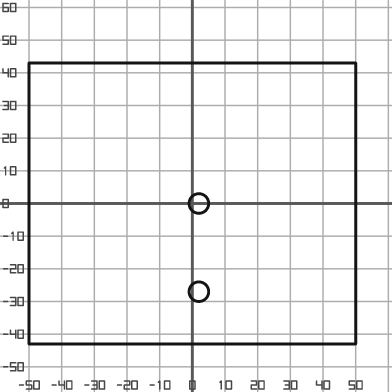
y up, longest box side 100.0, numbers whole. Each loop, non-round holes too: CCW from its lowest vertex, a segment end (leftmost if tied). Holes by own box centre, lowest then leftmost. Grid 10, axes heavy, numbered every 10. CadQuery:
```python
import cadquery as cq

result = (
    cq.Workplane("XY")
    .moveTo(-50.0, -43.0)
    .lineTo(50.0, -43.0)
    .lineTo(50.0, 43.0)
    .lineTo(-50.0, 43.0)
    .close()
    .moveTo(2.0, -27.0)
    .circle(3.0)
    .moveTo(2.0, 0.0)
    .circle(3.0)
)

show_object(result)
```